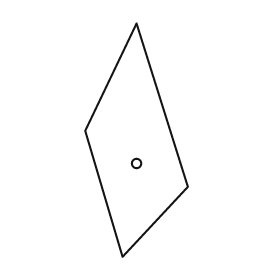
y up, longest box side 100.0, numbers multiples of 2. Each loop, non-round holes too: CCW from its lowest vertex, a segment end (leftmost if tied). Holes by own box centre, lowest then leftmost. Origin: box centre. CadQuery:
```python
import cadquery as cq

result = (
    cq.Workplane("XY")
    .moveTo(-6.0, -50.0)
    .lineTo(22.0, -20.0)
    .lineTo(0.0, 50.0)
    .lineTo(-22.0, 4.0)
    .close()
    .moveTo(0.0, -10.0)
    .circle(2.0)
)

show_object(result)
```